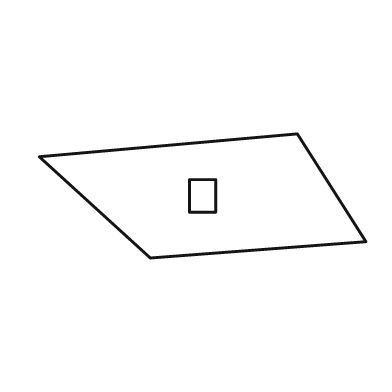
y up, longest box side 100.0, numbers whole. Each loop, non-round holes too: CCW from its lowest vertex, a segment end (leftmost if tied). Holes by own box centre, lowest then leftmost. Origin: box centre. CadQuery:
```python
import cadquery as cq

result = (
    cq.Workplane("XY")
    .moveTo(-16.0, -19.0)
    .lineTo(50.0, -14.0)
    .lineTo(29.0, 19.0)
    .lineTo(-50.0, 12.0)
    .close()
    .moveTo(-4.0, -5.0)
    .lineTo(4.0, -5.0)
    .lineTo(4.0, 5.0)
    .lineTo(-4.0, 5.0)
    .close()
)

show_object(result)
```